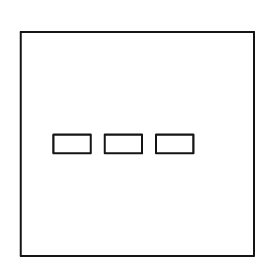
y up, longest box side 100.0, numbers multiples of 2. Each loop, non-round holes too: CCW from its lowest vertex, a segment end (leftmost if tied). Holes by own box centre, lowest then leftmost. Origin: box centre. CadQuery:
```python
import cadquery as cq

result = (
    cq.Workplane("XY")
    .moveTo(-50.0, -48.0)
    .lineTo(50.0, -48.0)
    .lineTo(50.0, 48.0)
    .lineTo(-50.0, 48.0)
    .close()
    .moveTo(-36.0, -4.0)
    .lineTo(-20.0, -4.0)
    .lineTo(-20.0, 4.0)
    .lineTo(-36.0, 4.0)
    .close()
    .moveTo(-14.0, -4.0)
    .lineTo(2.0, -4.0)
    .lineTo(2.0, 4.0)
    .lineTo(-14.0, 4.0)
    .close()
    .moveTo(8.0, -4.0)
    .lineTo(24.0, -4.0)
    .lineTo(24.0, 4.0)
    .lineTo(8.0, 4.0)
    .close()
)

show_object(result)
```